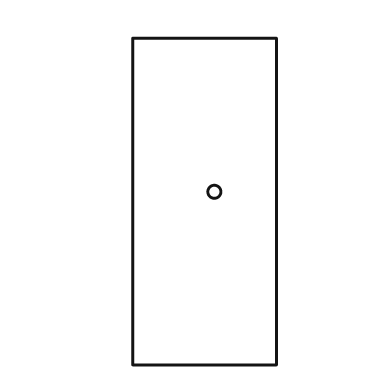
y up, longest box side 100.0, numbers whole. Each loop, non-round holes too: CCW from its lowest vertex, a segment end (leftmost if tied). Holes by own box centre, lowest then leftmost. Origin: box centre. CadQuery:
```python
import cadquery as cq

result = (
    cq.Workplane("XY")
    .moveTo(-22.0, -50.0)
    .lineTo(22.0, -50.0)
    .lineTo(22.0, 50.0)
    .lineTo(-22.0, 50.0)
    .close()
    .moveTo(3.0, 3.0)
    .circle(2.0)
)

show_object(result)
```